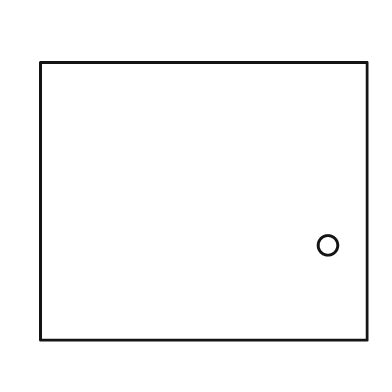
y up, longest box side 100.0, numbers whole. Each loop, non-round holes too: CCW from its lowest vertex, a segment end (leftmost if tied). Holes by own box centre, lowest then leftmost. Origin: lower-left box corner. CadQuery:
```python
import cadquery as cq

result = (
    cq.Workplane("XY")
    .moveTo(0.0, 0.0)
    .lineTo(100.0, 0.0)
    .lineTo(100.0, 85.0)
    .lineTo(0.0, 85.0)
    .close()
    .moveTo(88.0, 29.0)
    .circle(3.0)
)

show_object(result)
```